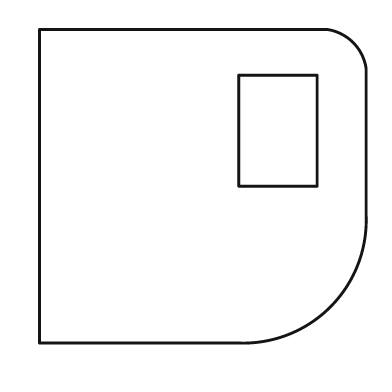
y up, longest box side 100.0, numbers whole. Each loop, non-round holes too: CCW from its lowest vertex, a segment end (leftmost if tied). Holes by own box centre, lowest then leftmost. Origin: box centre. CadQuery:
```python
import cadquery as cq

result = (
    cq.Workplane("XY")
    .moveTo(-50.0, -48.0)
    .lineTo(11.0, -48.0)
    .threePointArc((39.0, -37.0), (50.0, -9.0))
    .lineTo(50.0, 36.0)
    .threePointArc((46.0, 44.0), (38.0, 48.0))
    .lineTo(-50.0, 48.0)
    .close()
    .moveTo(11.0, 0.0)
    .lineTo(35.0, 0.0)
    .lineTo(35.0, 34.0)
    .lineTo(11.0, 34.0)
    .close()
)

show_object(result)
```